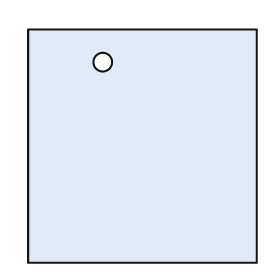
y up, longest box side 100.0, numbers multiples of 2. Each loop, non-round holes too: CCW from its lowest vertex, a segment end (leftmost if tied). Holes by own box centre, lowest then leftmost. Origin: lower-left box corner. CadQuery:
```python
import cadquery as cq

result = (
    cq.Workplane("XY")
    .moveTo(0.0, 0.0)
    .lineTo(98.0, 0.0)
    .lineTo(98.0, 100.0)
    .lineTo(0.0, 100.0)
    .close()
    .moveTo(32.0, 86.0)
    .circle(4.0)
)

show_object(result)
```